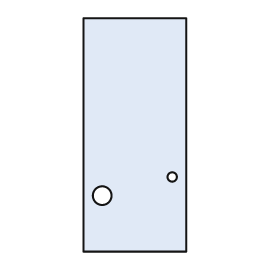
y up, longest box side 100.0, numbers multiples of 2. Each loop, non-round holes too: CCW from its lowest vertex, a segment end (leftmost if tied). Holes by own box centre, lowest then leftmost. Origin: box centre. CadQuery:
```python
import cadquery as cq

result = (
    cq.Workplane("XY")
    .moveTo(-22.0, -50.0)
    .lineTo(22.0, -50.0)
    .lineTo(22.0, 50.0)
    .lineTo(-22.0, 50.0)
    .close()
    .moveTo(-14.0, -26.0)
    .circle(4.0)
    .moveTo(16.0, -18.0)
    .circle(2.0)
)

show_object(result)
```